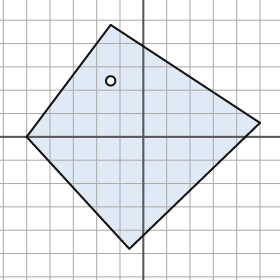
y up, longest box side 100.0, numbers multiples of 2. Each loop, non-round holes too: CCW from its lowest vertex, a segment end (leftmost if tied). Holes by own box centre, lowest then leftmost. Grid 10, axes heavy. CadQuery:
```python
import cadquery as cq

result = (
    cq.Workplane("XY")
    .moveTo(-6.0, -48.0)
    .lineTo(50.0, 6.0)
    .lineTo(-14.0, 48.0)
    .lineTo(-50.0, 0.0)
    .close()
    .moveTo(-14.0, 24.0)
    .circle(2.0)
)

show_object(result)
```